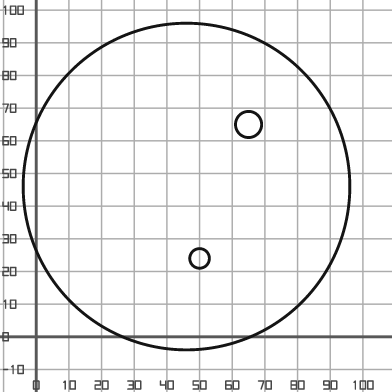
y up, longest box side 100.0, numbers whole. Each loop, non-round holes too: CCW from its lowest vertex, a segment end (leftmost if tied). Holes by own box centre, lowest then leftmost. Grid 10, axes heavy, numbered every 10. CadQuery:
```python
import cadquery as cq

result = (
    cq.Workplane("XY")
    .moveTo(46.0, 46.0)
    .circle(50.0)
    .moveTo(50.0, 24.0)
    .circle(3.0)
    .moveTo(65.0, 65.0)
    .circle(4.0)
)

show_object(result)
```